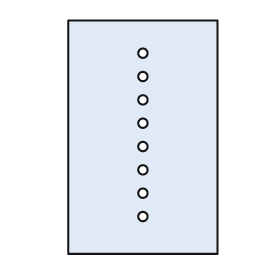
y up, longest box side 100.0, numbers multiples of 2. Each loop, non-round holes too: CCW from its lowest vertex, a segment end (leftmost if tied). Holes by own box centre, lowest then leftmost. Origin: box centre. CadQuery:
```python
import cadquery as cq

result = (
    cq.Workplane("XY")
    .moveTo(-32.0, -50.0)
    .lineTo(32.0, -50.0)
    .lineTo(32.0, 50.0)
    .lineTo(-32.0, 50.0)
    .close()
    .moveTo(0.0, -34.0)
    .circle(2.0)
    .moveTo(0.0, -24.0)
    .circle(2.0)
    .moveTo(0.0, -14.0)
    .circle(2.0)
    .moveTo(0.0, -4.0)
    .circle(2.0)
    .moveTo(0.0, 6.0)
    .circle(2.0)
    .moveTo(0.0, 16.0)
    .circle(2.0)
    .moveTo(0.0, 26.0)
    .circle(2.0)
    .moveTo(0.0, 36.0)
    .circle(2.0)
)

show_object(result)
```